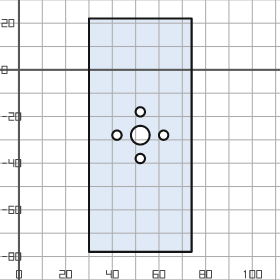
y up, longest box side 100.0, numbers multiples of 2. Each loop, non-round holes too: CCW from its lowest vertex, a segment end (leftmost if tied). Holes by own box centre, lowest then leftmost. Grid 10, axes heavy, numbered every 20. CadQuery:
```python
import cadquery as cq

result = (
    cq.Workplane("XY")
    .moveTo(30.0, -78.0)
    .lineTo(74.0, -78.0)
    .lineTo(74.0, 22.0)
    .lineTo(30.0, 22.0)
    .close()
    .moveTo(52.0, -38.0)
    .circle(2.0)
    .moveTo(42.0, -28.0)
    .circle(2.0)
    .moveTo(52.0, -28.0)
    .circle(4.0)
    .moveTo(62.0, -28.0)
    .circle(2.0)
    .moveTo(52.0, -18.0)
    .circle(2.0)
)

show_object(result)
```